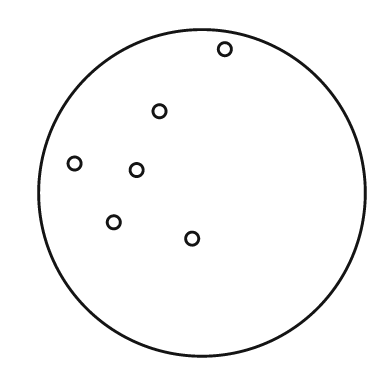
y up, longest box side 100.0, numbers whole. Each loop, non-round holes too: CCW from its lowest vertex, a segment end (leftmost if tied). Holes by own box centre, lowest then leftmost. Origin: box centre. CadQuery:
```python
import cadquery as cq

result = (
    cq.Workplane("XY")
    .moveTo(0.0, 0.0)
    .circle(50.0)
    .moveTo(-3.0, -14.0)
    .circle(2.0)
    .moveTo(-27.0, -9.0)
    .circle(2.0)
    .moveTo(-20.0, 7.0)
    .circle(2.0)
    .moveTo(-39.0, 9.0)
    .circle(2.0)
    .moveTo(-13.0, 25.0)
    .circle(2.0)
    .moveTo(7.0, 44.0)
    .circle(2.0)
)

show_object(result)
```